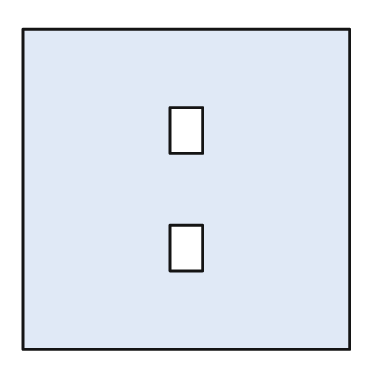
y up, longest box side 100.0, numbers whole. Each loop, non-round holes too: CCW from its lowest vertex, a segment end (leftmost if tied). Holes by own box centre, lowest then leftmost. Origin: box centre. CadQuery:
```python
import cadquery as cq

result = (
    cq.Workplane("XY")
    .moveTo(-50.0, -49.0)
    .lineTo(50.0, -49.0)
    .lineTo(50.0, 49.0)
    .lineTo(-50.0, 49.0)
    .close()
    .moveTo(-5.0, -25.0)
    .lineTo(5.0, -25.0)
    .lineTo(5.0, -11.0)
    .lineTo(-5.0, -11.0)
    .close()
    .moveTo(-5.0, 11.0)
    .lineTo(5.0, 11.0)
    .lineTo(5.0, 25.0)
    .lineTo(-5.0, 25.0)
    .close()
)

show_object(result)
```